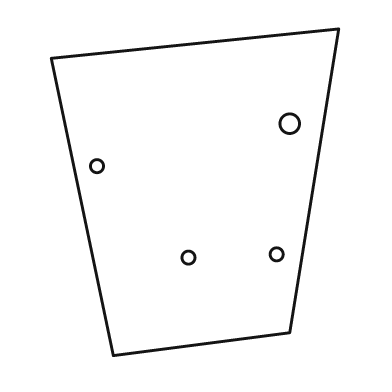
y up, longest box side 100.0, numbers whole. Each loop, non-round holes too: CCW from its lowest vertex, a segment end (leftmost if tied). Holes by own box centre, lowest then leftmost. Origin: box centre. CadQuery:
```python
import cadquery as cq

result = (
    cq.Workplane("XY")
    .moveTo(-25.0, -50.0)
    .lineTo(29.0, -43.0)
    .lineTo(44.0, 50.0)
    .lineTo(-44.0, 41.0)
    .close()
    .moveTo(-2.0, -20.0)
    .circle(2.0)
    .moveTo(25.0, -19.0)
    .circle(2.0)
    .moveTo(-30.0, 8.0)
    .circle(2.0)
    .moveTo(29.0, 21.0)
    .circle(3.0)
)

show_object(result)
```